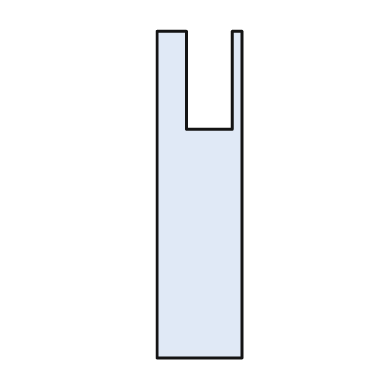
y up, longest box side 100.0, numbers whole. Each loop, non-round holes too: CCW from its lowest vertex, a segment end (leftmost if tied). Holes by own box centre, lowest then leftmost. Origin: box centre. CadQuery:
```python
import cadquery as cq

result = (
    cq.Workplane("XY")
    .moveTo(-13.0, -50.0)
    .lineTo(13.0, -50.0)
    .lineTo(13.0, 50.0)
    .lineTo(10.0, 50.0)
    .lineTo(10.0, 20.0)
    .lineTo(-4.0, 20.0)
    .lineTo(-4.0, 50.0)
    .lineTo(-13.0, 50.0)
    .close()
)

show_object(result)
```